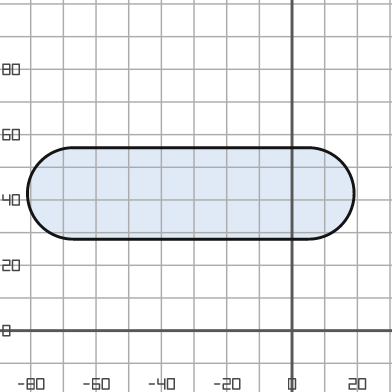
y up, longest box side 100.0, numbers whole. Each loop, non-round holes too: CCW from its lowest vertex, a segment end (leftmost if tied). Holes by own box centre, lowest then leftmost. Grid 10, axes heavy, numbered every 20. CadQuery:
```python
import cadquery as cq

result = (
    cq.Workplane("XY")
    .moveTo(-67.0, 28.0)
    .lineTo(5.0, 28.0)
    .threePointArc((19.0, 42.0), (5.0, 56.0))
    .lineTo(-67.0, 56.0)
    .threePointArc((-81.0, 42.0), (-67.0, 28.0))
    .close()
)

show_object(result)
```